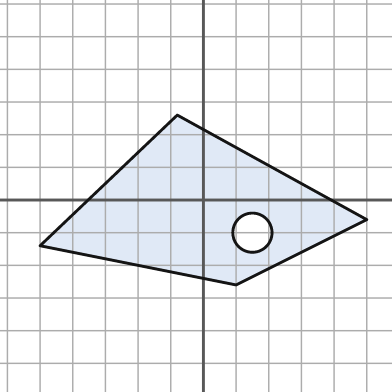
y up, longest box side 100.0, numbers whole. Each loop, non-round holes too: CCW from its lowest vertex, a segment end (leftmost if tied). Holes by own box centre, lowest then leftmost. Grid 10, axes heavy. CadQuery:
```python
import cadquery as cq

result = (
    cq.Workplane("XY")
    .moveTo(10.0, -26.0)
    .lineTo(50.0, -6.0)
    .lineTo(-8.0, 26.0)
    .lineTo(-50.0, -14.0)
    .close()
    .moveTo(15.0, -10.0)
    .circle(6.0)
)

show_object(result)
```